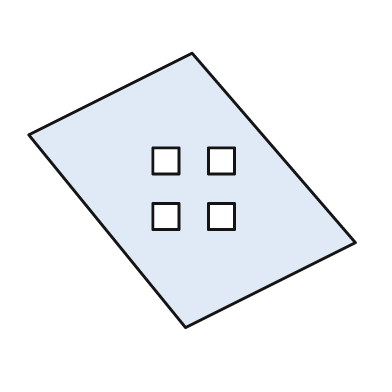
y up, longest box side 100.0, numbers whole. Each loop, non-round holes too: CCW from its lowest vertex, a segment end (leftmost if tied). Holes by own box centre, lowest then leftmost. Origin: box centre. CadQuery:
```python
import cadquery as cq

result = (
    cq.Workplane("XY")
    .moveTo(-2.0, -42.0)
    .lineTo(50.0, -16.0)
    .lineTo(0.0, 42.0)
    .lineTo(-50.0, 17.0)
    .close()
    .moveTo(-12.0, -12.0)
    .lineTo(-4.0, -12.0)
    .lineTo(-4.0, -4.0)
    .lineTo(-12.0, -4.0)
    .close()
    .moveTo(5.0, -12.0)
    .lineTo(13.0, -12.0)
    .lineTo(13.0, -4.0)
    .lineTo(5.0, -4.0)
    .close()
    .moveTo(-12.0, 5.0)
    .lineTo(-4.0, 5.0)
    .lineTo(-4.0, 13.0)
    .lineTo(-12.0, 13.0)
    .close()
    .moveTo(5.0, 5.0)
    .lineTo(13.0, 5.0)
    .lineTo(13.0, 13.0)
    .lineTo(5.0, 13.0)
    .close()
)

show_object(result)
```